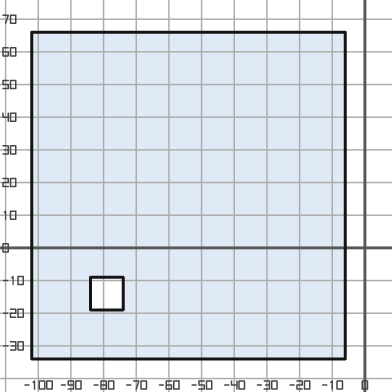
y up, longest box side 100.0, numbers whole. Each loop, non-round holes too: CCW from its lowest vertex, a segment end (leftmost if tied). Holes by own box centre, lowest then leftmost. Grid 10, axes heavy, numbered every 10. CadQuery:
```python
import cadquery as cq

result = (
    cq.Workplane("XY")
    .moveTo(-102.0, -34.0)
    .lineTo(-6.0, -34.0)
    .lineTo(-6.0, 66.0)
    .lineTo(-102.0, 66.0)
    .close()
    .moveTo(-84.0, -19.0)
    .lineTo(-74.0, -19.0)
    .lineTo(-74.0, -9.0)
    .lineTo(-84.0, -9.0)
    .close()
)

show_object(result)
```